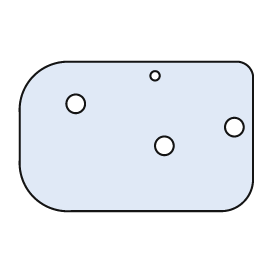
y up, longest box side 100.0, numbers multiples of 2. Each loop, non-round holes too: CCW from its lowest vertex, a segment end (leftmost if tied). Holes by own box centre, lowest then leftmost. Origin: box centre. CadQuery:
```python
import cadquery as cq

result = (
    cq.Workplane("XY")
    .moveTo(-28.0, -32.0)
    .lineTo(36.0, -32.0)
    .threePointArc((46.0, -28.0), (50.0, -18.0))
    .lineTo(50.0, 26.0)
    .threePointArc((48.0, 30.0), (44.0, 32.0))
    .lineTo(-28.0, 32.0)
    .threePointArc((-44.0, 26.0), (-50.0, 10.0))
    .lineTo(-50.0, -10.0)
    .threePointArc((-44.0, -26.0), (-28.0, -32.0))
    .close()
    .moveTo(12.0, -4.0)
    .circle(4.0)
    .moveTo(42.0, 4.0)
    .circle(4.0)
    .moveTo(-26.0, 14.0)
    .circle(4.0)
    .moveTo(8.0, 26.0)
    .circle(2.0)
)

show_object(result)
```